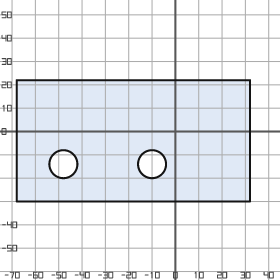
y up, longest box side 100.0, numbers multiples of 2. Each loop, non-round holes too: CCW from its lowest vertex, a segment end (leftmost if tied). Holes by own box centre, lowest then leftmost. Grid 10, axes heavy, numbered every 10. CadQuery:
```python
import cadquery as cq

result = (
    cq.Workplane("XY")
    .moveTo(-68.0, -30.0)
    .lineTo(32.0, -30.0)
    .lineTo(32.0, 22.0)
    .lineTo(-68.0, 22.0)
    .close()
    .moveTo(-48.0, -14.0)
    .circle(6.0)
    .moveTo(-10.0, -14.0)
    .circle(6.0)
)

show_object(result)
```